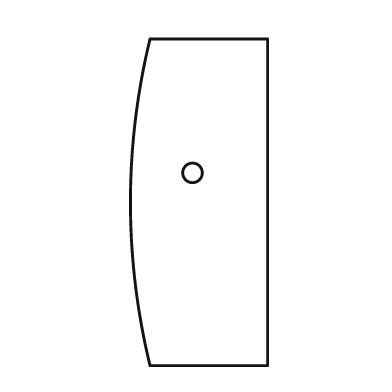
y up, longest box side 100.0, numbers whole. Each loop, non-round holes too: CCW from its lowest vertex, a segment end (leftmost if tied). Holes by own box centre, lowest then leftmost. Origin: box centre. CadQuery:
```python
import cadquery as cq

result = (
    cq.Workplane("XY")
    .moveTo(-15.0, -50.0)
    .lineTo(21.0, -50.0)
    .lineTo(21.0, 50.0)
    .lineTo(-15.0, 50.0)
    .threePointArc((-21.0, 0.0), (-15.0, -50.0))
    .close()
    .moveTo(-2.0, 9.0)
    .circle(3.0)
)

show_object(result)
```